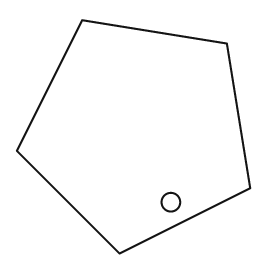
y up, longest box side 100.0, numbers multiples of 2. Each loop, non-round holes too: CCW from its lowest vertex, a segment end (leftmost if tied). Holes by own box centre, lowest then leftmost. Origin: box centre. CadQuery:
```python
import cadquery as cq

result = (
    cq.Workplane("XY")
    .moveTo(-6.0, -50.0)
    .lineTo(50.0, -22.0)
    .lineTo(40.0, 40.0)
    .lineTo(-22.0, 50.0)
    .lineTo(-50.0, -6.0)
    .close()
    .moveTo(16.0, -28.0)
    .circle(4.0)
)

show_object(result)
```